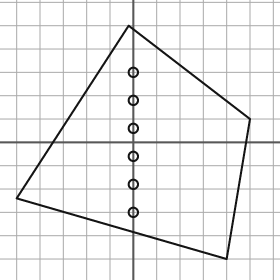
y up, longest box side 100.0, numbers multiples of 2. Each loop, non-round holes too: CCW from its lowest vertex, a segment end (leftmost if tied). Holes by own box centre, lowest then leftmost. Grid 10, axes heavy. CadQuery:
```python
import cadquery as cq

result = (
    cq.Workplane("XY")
    .moveTo(40.0, -50.0)
    .lineTo(50.0, 10.0)
    .lineTo(-2.0, 50.0)
    .lineTo(-50.0, -24.0)
    .close()
    .moveTo(0.0, -30.0)
    .circle(2.0)
    .moveTo(0.0, -18.0)
    .circle(2.0)
    .moveTo(0.0, -6.0)
    .circle(2.0)
    .moveTo(0.0, 6.0)
    .circle(2.0)
    .moveTo(0.0, 18.0)
    .circle(2.0)
    .moveTo(0.0, 30.0)
    .circle(2.0)
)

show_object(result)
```